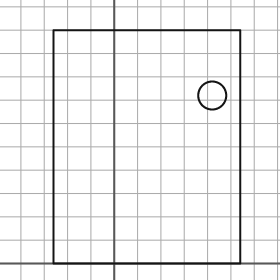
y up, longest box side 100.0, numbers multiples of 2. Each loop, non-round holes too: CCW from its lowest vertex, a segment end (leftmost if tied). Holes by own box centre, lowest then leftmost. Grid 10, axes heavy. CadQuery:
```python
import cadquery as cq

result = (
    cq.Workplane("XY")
    .moveTo(-26.0, 0.0)
    .lineTo(54.0, 0.0)
    .lineTo(54.0, 100.0)
    .lineTo(-26.0, 100.0)
    .close()
    .moveTo(42.0, 72.0)
    .circle(6.0)
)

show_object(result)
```